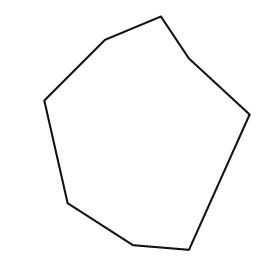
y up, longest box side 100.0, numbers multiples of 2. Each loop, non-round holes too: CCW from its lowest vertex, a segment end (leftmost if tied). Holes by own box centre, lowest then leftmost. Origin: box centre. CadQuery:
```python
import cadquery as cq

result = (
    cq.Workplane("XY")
    .moveTo(18.0, -50.0)
    .lineTo(44.0, 8.0)
    .lineTo(18.0, 32.0)
    .lineTo(6.0, 50.0)
    .lineTo(-18.0, 40.0)
    .lineTo(-44.0, 14.0)
    .lineTo(-34.0, -30.0)
    .lineTo(-6.0, -48.0)
    .close()
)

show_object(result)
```